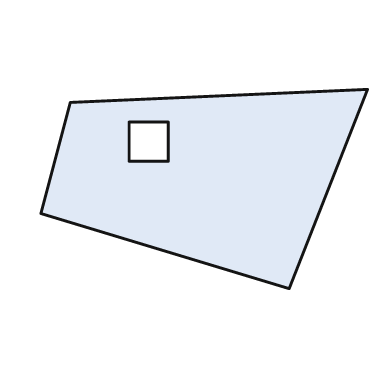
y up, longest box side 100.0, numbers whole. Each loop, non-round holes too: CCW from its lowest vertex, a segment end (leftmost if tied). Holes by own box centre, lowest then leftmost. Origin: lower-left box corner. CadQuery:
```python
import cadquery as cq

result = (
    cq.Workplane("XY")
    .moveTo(76.0, 0.0)
    .lineTo(100.0, 61.0)
    .lineTo(9.0, 57.0)
    .lineTo(0.0, 23.0)
    .close()
    .moveTo(27.0, 39.0)
    .lineTo(39.0, 39.0)
    .lineTo(39.0, 51.0)
    .lineTo(27.0, 51.0)
    .close()
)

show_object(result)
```